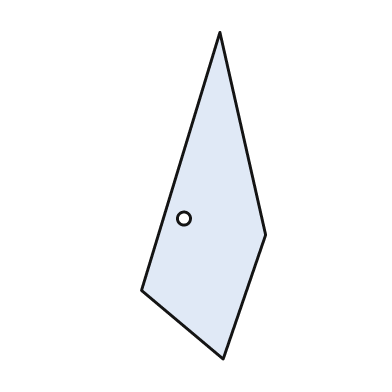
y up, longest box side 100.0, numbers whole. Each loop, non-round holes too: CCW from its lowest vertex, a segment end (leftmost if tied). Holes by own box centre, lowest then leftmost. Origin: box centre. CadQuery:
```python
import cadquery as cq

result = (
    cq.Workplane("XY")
    .moveTo(6.0, -50.0)
    .lineTo(19.0, -12.0)
    .lineTo(5.0, 50.0)
    .lineTo(-19.0, -29.0)
    .close()
    .moveTo(-6.0, -7.0)
    .circle(2.0)
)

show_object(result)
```